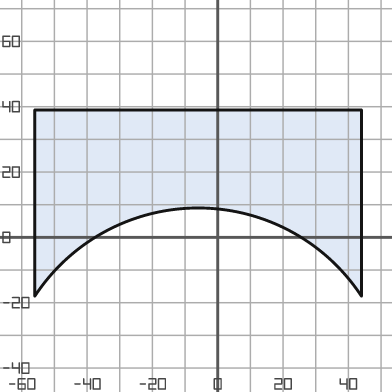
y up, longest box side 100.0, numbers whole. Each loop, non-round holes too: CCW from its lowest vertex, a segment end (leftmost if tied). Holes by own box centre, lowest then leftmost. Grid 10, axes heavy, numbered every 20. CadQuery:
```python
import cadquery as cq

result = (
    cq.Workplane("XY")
    .moveTo(-56.0, -18.0)
    .threePointArc((-6.0, 9.0), (44.0, -18.0))
    .lineTo(44.0, 39.0)
    .lineTo(-56.0, 39.0)
    .close()
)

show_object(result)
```